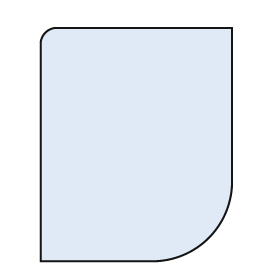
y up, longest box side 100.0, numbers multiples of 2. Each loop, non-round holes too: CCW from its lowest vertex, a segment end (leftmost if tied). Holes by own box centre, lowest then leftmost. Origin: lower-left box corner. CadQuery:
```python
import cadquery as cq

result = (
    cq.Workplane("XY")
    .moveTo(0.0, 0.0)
    .lineTo(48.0, 0.0)
    .threePointArc((72.0, 10.0), (82.0, 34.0))
    .lineTo(82.0, 100.0)
    .lineTo(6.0, 100.0)
    .threePointArc((2.0, 98.0), (0.0, 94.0))
    .close()
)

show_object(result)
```